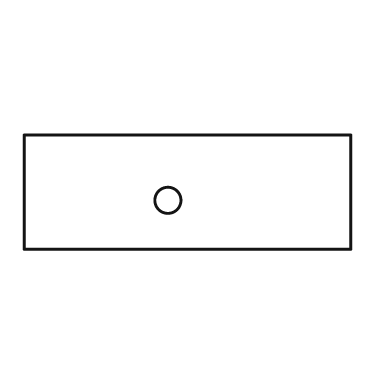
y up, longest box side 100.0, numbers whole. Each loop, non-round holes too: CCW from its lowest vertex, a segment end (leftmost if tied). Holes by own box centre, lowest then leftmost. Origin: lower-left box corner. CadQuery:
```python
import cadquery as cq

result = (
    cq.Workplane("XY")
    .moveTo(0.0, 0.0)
    .lineTo(100.0, 0.0)
    .lineTo(100.0, 35.0)
    .lineTo(0.0, 35.0)
    .close()
    .moveTo(44.0, 15.0)
    .circle(4.0)
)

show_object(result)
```